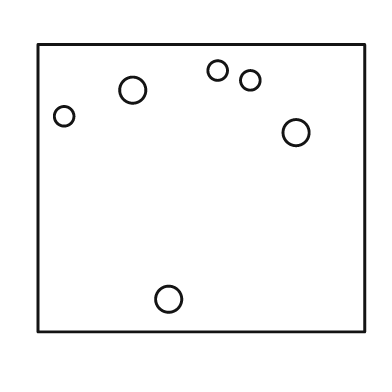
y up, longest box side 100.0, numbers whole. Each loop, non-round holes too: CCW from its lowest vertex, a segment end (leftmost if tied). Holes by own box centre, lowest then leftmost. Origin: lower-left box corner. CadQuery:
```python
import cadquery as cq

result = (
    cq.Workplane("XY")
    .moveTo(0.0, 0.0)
    .lineTo(100.0, 0.0)
    .lineTo(100.0, 88.0)
    .lineTo(0.0, 88.0)
    .close()
    .moveTo(40.0, 10.0)
    .circle(4.0)
    .moveTo(79.0, 61.0)
    .circle(4.0)
    .moveTo(8.0, 66.0)
    .circle(3.0)
    .moveTo(29.0, 74.0)
    .circle(4.0)
    .moveTo(65.0, 77.0)
    .circle(3.0)
    .moveTo(55.0, 80.0)
    .circle(3.0)
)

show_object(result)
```